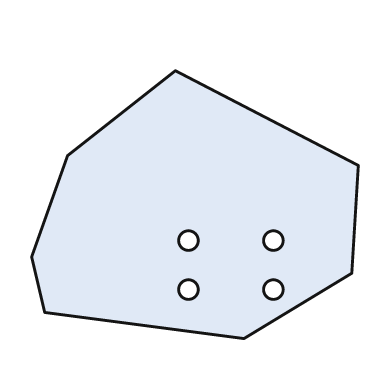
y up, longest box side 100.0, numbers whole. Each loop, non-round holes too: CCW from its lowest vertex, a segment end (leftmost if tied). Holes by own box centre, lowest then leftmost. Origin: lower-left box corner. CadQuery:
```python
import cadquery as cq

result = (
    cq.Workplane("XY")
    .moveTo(65.0, 0.0)
    .lineTo(98.0, 20.0)
    .lineTo(100.0, 53.0)
    .lineTo(44.0, 82.0)
    .lineTo(11.0, 56.0)
    .lineTo(0.0, 25.0)
    .lineTo(4.0, 8.0)
    .close()
    .moveTo(48.0, 15.0)
    .circle(3.0)
    .moveTo(74.0, 15.0)
    .circle(3.0)
    .moveTo(48.0, 30.0)
    .circle(3.0)
    .moveTo(74.0, 30.0)
    .circle(3.0)
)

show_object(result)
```